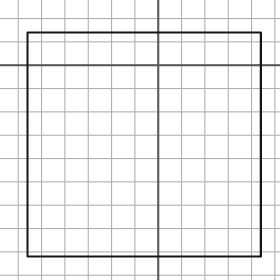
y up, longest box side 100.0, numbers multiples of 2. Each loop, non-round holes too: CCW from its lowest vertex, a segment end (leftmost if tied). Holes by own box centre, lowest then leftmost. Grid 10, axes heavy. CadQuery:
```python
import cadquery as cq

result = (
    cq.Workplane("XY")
    .moveTo(-56.0, -82.0)
    .lineTo(44.0, -82.0)
    .lineTo(44.0, 14.0)
    .lineTo(-56.0, 14.0)
    .close()
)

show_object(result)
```